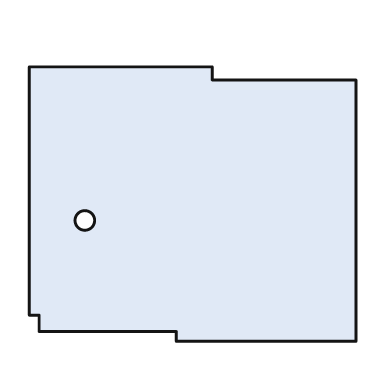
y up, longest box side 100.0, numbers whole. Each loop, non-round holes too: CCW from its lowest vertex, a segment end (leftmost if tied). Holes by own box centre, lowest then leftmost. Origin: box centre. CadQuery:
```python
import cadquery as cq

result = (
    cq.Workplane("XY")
    .moveTo(-5.0, -42.0)
    .lineTo(50.0, -42.0)
    .lineTo(50.0, 38.0)
    .lineTo(6.0, 38.0)
    .lineTo(6.0, 42.0)
    .lineTo(-50.0, 42.0)
    .lineTo(-50.0, -34.0)
    .lineTo(-47.0, -34.0)
    .lineTo(-47.0, -39.0)
    .lineTo(-5.0, -39.0)
    .close()
    .moveTo(-33.0, -5.0)
    .circle(3.0)
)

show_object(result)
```